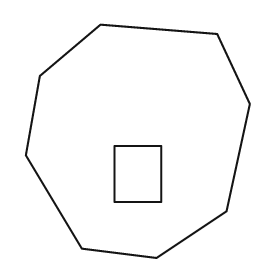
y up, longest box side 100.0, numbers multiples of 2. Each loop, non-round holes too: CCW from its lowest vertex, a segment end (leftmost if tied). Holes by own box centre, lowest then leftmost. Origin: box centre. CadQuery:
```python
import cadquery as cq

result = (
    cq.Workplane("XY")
    .moveTo(8.0, -50.0)
    .lineTo(38.0, -30.0)
    .lineTo(48.0, 16.0)
    .lineTo(34.0, 46.0)
    .lineTo(-16.0, 50.0)
    .lineTo(-42.0, 28.0)
    .lineTo(-48.0, -6.0)
    .lineTo(-24.0, -46.0)
    .close()
    .moveTo(-10.0, -26.0)
    .lineTo(10.0, -26.0)
    .lineTo(10.0, -2.0)
    .lineTo(-10.0, -2.0)
    .close()
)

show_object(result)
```